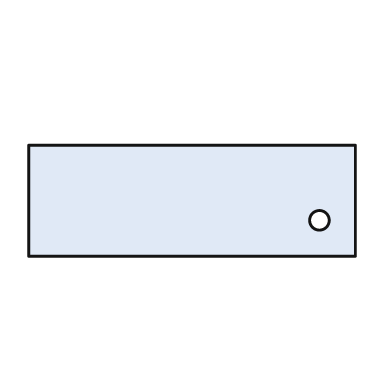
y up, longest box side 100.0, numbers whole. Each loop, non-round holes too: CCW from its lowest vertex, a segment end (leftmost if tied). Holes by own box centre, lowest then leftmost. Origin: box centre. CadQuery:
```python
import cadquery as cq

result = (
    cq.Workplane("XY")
    .moveTo(-50.0, -17.0)
    .lineTo(50.0, -17.0)
    .lineTo(50.0, 17.0)
    .lineTo(-50.0, 17.0)
    .close()
    .moveTo(39.0, -6.0)
    .circle(3.0)
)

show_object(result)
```